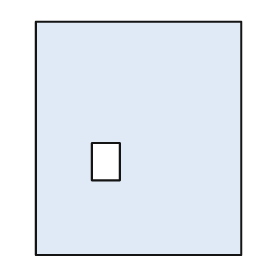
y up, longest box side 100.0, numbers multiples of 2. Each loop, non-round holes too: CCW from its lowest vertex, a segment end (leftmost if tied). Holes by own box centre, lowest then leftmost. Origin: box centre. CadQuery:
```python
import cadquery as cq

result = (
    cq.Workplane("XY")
    .moveTo(-44.0, -50.0)
    .lineTo(44.0, -50.0)
    .lineTo(44.0, 50.0)
    .lineTo(-44.0, 50.0)
    .close()
    .moveTo(-20.0, -18.0)
    .lineTo(-8.0, -18.0)
    .lineTo(-8.0, -2.0)
    .lineTo(-20.0, -2.0)
    .close()
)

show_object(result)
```